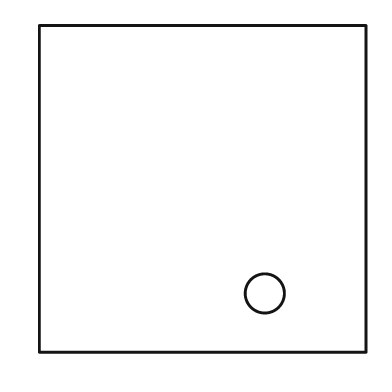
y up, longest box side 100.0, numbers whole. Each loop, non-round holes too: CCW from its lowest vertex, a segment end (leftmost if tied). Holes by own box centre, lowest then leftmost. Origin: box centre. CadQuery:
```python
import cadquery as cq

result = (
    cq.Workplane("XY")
    .moveTo(-50.0, -50.0)
    .lineTo(50.0, -50.0)
    .lineTo(50.0, 50.0)
    .lineTo(-50.0, 50.0)
    .close()
    .moveTo(19.0, -32.0)
    .circle(6.0)
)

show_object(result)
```